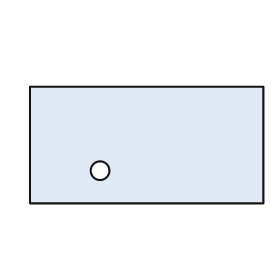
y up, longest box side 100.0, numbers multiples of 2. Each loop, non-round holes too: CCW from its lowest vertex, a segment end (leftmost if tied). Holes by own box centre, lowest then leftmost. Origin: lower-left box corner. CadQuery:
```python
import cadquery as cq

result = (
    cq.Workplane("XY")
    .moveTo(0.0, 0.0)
    .lineTo(100.0, 0.0)
    .lineTo(100.0, 50.0)
    .lineTo(0.0, 50.0)
    .close()
    .moveTo(30.0, 14.0)
    .circle(4.0)
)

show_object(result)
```